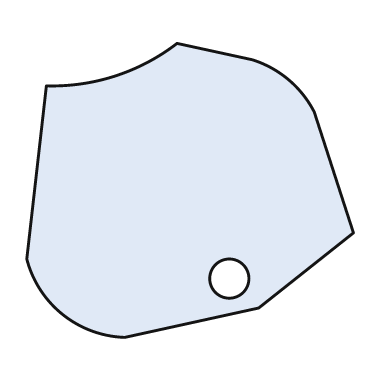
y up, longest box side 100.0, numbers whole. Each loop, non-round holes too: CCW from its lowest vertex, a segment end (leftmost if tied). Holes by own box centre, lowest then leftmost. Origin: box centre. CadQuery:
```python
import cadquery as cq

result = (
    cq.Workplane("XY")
    .moveTo(-20.0, -45.0)
    .lineTo(21.0, -36.0)
    .lineTo(50.0, -13.0)
    .lineTo(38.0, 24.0)
    .threePointArc((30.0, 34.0), (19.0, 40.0))
    .lineTo(-4.0, 45.0)
    .threePointArc((-23.0, 35.0), (-44.0, 32.0))
    .lineTo(-50.0, -21.0)
    .threePointArc((-39.0, -38.0), (-20.0, -45.0))
    .close()
    .moveTo(12.0, -27.0)
    .circle(6.0)
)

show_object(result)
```